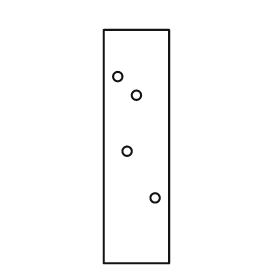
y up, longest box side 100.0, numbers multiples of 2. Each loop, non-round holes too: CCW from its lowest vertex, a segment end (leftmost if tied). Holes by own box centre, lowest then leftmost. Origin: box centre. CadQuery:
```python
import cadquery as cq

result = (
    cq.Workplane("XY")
    .moveTo(-14.0, -50.0)
    .lineTo(14.0, -50.0)
    .lineTo(14.0, 50.0)
    .lineTo(-14.0, 50.0)
    .close()
    .moveTo(8.0, -22.0)
    .circle(2.0)
    .moveTo(-4.0, -2.0)
    .circle(2.0)
    .moveTo(0.0, 22.0)
    .circle(2.0)
    .moveTo(-8.0, 30.0)
    .circle(2.0)
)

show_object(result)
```